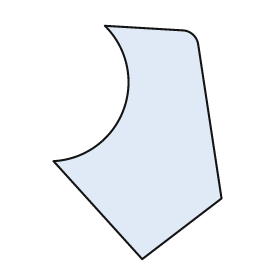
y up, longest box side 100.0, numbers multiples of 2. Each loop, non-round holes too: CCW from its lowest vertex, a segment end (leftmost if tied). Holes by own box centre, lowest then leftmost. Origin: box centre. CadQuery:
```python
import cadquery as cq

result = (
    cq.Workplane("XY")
    .moveTo(2.0, -50.0)
    .lineTo(36.0, -24.0)
    .lineTo(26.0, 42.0)
    .threePointArc((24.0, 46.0), (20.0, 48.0))
    .lineTo(-14.0, 50.0)
    .threePointArc((-6.0, 14.0), (-36.0, -8.0))
    .close()
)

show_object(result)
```